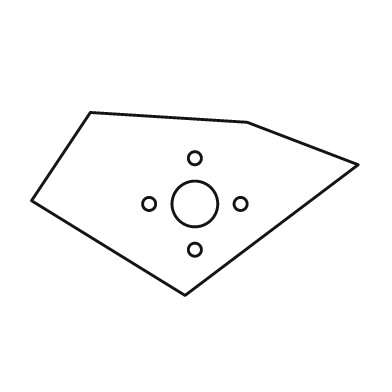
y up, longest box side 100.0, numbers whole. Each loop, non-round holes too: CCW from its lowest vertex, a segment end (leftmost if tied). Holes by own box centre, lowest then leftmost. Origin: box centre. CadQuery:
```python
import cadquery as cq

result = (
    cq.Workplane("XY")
    .moveTo(-3.0, -28.0)
    .lineTo(50.0, 12.0)
    .lineTo(16.0, 25.0)
    .lineTo(-32.0, 28.0)
    .lineTo(-50.0, 1.0)
    .close()
    .moveTo(0.0, -14.0)
    .circle(2.0)
    .moveTo(-14.0, 0.0)
    .circle(2.0)
    .moveTo(0.0, 0.0)
    .circle(7.0)
    .moveTo(14.0, 0.0)
    .circle(2.0)
    .moveTo(0.0, 14.0)
    .circle(2.0)
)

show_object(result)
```